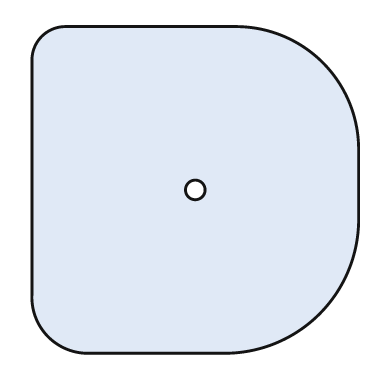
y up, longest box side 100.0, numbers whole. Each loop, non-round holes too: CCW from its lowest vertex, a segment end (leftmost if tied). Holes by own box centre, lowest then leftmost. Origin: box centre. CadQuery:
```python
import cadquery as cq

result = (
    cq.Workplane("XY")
    .moveTo(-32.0, -50.0)
    .lineTo(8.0, -50.0)
    .threePointArc((38.0, -38.0), (50.0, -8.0))
    .lineTo(50.0, 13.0)
    .threePointArc((39.0, 39.0), (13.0, 50.0))
    .lineTo(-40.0, 50.0)
    .threePointArc((-47.0, 47.0), (-50.0, 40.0))
    .lineTo(-50.0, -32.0)
    .threePointArc((-45.0, -45.0), (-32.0, -50.0))
    .close()
    .moveTo(0.0, 0.0)
    .circle(3.0)
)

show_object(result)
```